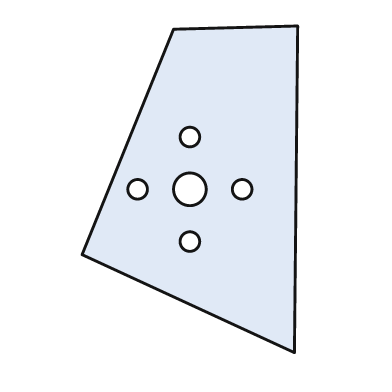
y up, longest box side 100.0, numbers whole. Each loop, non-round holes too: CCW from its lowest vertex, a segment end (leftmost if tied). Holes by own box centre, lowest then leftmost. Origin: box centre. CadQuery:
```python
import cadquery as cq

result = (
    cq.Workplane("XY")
    .moveTo(32.0, -50.0)
    .lineTo(33.0, 50.0)
    .lineTo(-5.0, 49.0)
    .lineTo(-33.0, -20.0)
    .close()
    .moveTo(0.0, -16.0)
    .circle(3.0)
    .moveTo(-16.0, 0.0)
    .circle(3.0)
    .moveTo(0.0, 0.0)
    .circle(5.0)
    .moveTo(16.0, 0.0)
    .circle(3.0)
    .moveTo(0.0, 16.0)
    .circle(3.0)
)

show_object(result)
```